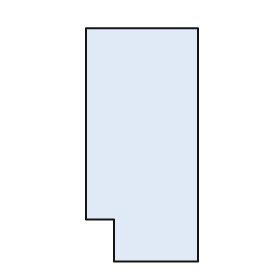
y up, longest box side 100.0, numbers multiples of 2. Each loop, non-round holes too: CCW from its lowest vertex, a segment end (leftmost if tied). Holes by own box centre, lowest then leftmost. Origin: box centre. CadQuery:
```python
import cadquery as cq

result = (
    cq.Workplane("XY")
    .moveTo(-12.0, -50.0)
    .lineTo(24.0, -50.0)
    .lineTo(24.0, 50.0)
    .lineTo(-24.0, 50.0)
    .lineTo(-24.0, -32.0)
    .lineTo(-12.0, -32.0)
    .close()
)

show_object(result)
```